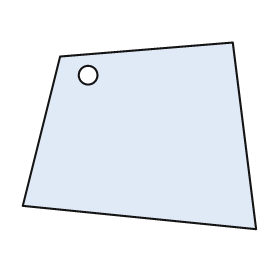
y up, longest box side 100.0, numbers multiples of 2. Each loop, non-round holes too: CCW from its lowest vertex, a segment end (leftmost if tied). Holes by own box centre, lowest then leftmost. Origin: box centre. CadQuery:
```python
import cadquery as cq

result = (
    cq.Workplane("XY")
    .moveTo(50.0, -40.0)
    .lineTo(40.0, 40.0)
    .lineTo(-34.0, 34.0)
    .lineTo(-50.0, -30.0)
    .close()
    .moveTo(-22.0, 26.0)
    .circle(4.0)
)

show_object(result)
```